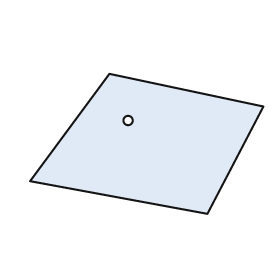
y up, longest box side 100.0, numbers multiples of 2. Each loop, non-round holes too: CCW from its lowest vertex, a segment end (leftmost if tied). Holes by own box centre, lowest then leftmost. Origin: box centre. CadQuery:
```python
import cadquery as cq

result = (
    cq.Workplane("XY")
    .moveTo(26.0, -30.0)
    .lineTo(50.0, 16.0)
    .lineTo(-16.0, 30.0)
    .lineTo(-50.0, -16.0)
    .close()
    .moveTo(-8.0, 10.0)
    .circle(2.0)
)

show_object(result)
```